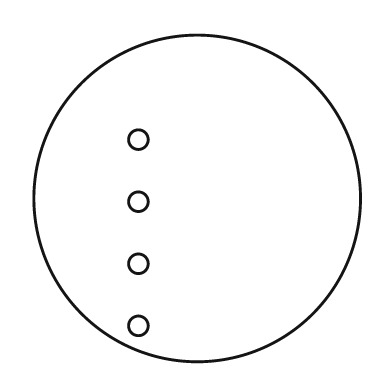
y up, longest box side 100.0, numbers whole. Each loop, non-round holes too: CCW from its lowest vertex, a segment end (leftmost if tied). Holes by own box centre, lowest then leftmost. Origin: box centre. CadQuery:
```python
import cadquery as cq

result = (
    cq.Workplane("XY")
    .moveTo(0.0, 0.0)
    .circle(50.0)
    .moveTo(-18.0, -39.0)
    .circle(3.0)
    .moveTo(-18.0, -20.0)
    .circle(3.0)
    .moveTo(-18.0, -1.0)
    .circle(3.0)
    .moveTo(-18.0, 18.0)
    .circle(3.0)
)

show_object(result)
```